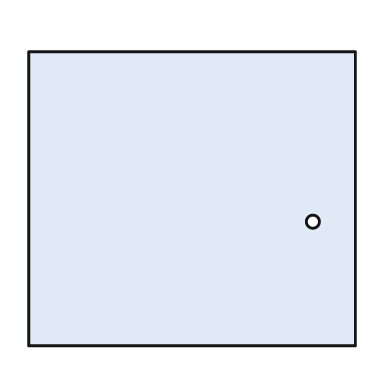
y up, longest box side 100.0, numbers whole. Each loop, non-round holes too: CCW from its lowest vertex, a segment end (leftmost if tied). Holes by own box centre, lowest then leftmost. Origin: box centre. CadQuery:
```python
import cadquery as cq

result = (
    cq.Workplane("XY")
    .moveTo(-50.0, -45.0)
    .lineTo(50.0, -45.0)
    .lineTo(50.0, 45.0)
    .lineTo(-50.0, 45.0)
    .close()
    .moveTo(37.0, -7.0)
    .circle(2.0)
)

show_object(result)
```